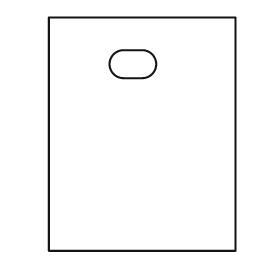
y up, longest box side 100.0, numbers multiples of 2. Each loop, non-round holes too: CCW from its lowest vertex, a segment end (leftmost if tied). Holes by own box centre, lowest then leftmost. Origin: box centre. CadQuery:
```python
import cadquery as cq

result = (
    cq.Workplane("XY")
    .moveTo(-40.0, -50.0)
    .lineTo(40.0, -50.0)
    .lineTo(40.0, 50.0)
    .lineTo(-40.0, 50.0)
    .close()
    .moveTo(-8.0, 24.0)
    .lineTo(0.0, 24.0)
    .threePointArc((6.0, 30.0), (0.0, 36.0))
    .lineTo(-8.0, 36.0)
    .threePointArc((-14.0, 30.0), (-8.0, 24.0))
    .close()
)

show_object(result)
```